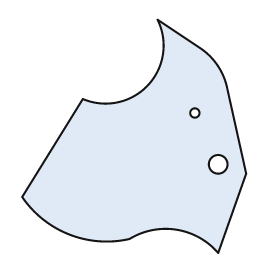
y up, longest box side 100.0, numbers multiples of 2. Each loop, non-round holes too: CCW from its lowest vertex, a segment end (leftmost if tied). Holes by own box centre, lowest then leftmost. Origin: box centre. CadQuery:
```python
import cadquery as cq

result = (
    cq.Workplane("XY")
    .moveTo(36.0, -50.0)
    .lineTo(48.0, -16.0)
    .lineTo(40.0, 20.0)
    .threePointArc((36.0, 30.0), (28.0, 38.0))
    .lineTo(10.0, 50.0)
    .threePointArc((6.0, 22.0), (-22.0, 16.0))
    .lineTo(-48.0, -26.0)
    .threePointArc((-28.0, -42.0), (-2.0, -44.0))
    .threePointArc((18.0, -40.0), (36.0, -50.0))
    .close()
    .moveTo(36.0, -12.0)
    .circle(4.0)
    .moveTo(26.0, 10.0)
    .circle(2.0)
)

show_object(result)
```